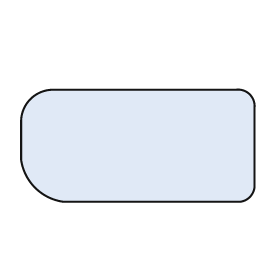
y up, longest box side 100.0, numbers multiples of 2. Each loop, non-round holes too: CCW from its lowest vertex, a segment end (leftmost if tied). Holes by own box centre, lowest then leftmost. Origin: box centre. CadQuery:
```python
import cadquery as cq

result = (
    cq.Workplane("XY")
    .moveTo(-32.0, -24.0)
    .lineTo(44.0, -24.0)
    .threePointArc((48.0, -22.0), (50.0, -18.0))
    .lineTo(50.0, 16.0)
    .threePointArc((48.0, 22.0), (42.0, 24.0))
    .lineTo(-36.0, 24.0)
    .threePointArc((-46.0, 20.0), (-50.0, 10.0))
    .lineTo(-50.0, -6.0)
    .threePointArc((-44.0, -18.0), (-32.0, -24.0))
    .close()
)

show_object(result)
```